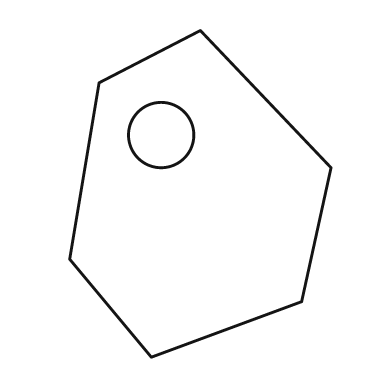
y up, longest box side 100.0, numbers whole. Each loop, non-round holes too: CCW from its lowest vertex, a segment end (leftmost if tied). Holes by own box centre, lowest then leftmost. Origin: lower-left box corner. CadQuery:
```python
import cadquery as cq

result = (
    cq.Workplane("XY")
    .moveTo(25.0, 0.0)
    .lineTo(71.0, 17.0)
    .lineTo(80.0, 58.0)
    .lineTo(40.0, 100.0)
    .lineTo(9.0, 84.0)
    .lineTo(0.0, 30.0)
    .close()
    .moveTo(28.0, 68.0)
    .circle(10.0)
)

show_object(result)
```